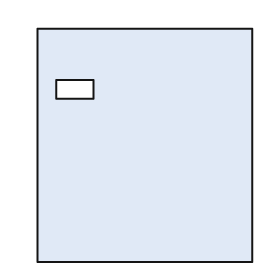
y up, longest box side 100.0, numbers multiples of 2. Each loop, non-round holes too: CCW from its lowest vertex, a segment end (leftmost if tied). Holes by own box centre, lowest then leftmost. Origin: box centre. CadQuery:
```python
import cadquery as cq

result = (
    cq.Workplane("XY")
    .moveTo(-46.0, -50.0)
    .lineTo(46.0, -50.0)
    .lineTo(46.0, 50.0)
    .lineTo(-46.0, 50.0)
    .close()
    .moveTo(-38.0, 20.0)
    .lineTo(-22.0, 20.0)
    .lineTo(-22.0, 28.0)
    .lineTo(-38.0, 28.0)
    .close()
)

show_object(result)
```